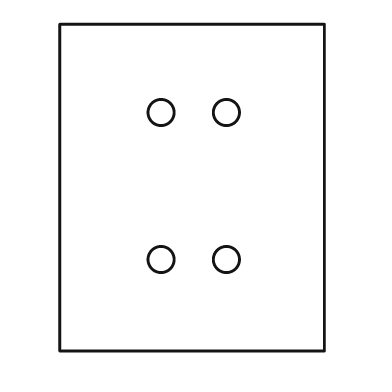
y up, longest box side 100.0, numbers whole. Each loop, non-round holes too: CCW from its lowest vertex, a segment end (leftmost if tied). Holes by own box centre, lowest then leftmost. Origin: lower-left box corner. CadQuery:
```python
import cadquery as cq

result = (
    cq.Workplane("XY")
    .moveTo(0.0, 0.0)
    .lineTo(81.0, 0.0)
    .lineTo(81.0, 100.0)
    .lineTo(0.0, 100.0)
    .close()
    .moveTo(31.0, 28.0)
    .circle(4.0)
    .moveTo(51.0, 28.0)
    .circle(4.0)
    .moveTo(31.0, 73.0)
    .circle(4.0)
    .moveTo(51.0, 73.0)
    .circle(4.0)
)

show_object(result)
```